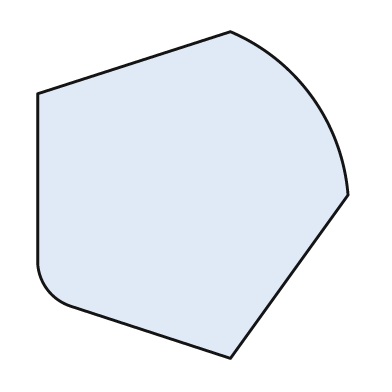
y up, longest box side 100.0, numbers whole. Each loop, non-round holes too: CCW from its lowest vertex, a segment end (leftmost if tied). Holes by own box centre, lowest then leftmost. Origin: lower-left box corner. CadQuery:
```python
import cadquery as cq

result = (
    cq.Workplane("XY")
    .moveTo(59.0, 0.0)
    .lineTo(95.0, 50.0)
    .threePointArc((84.0, 80.0), (59.0, 100.0))
    .lineTo(0.0, 81.0)
    .lineTo(0.0, 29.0)
    .threePointArc((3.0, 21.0), (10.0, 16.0))
    .close()
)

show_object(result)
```